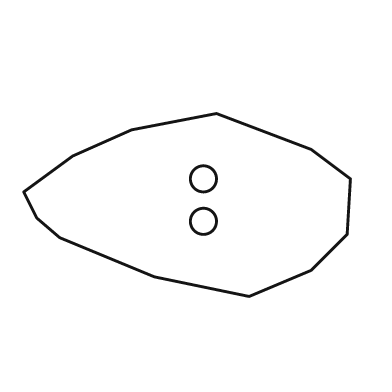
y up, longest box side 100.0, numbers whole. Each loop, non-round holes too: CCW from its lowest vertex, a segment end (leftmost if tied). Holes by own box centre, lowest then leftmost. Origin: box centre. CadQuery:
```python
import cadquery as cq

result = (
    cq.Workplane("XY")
    .moveTo(19.0, -28.0)
    .lineTo(38.0, -20.0)
    .lineTo(49.0, -9.0)
    .lineTo(50.0, 8.0)
    .lineTo(38.0, 17.0)
    .lineTo(9.0, 28.0)
    .lineTo(-17.0, 23.0)
    .lineTo(-35.0, 15.0)
    .lineTo(-50.0, 4.0)
    .lineTo(-46.0, -4.0)
    .lineTo(-39.0, -10.0)
    .lineTo(-10.0, -22.0)
    .close()
    .moveTo(5.0, -5.0)
    .circle(4.0)
    .moveTo(5.0, 8.0)
    .circle(4.0)
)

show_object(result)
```